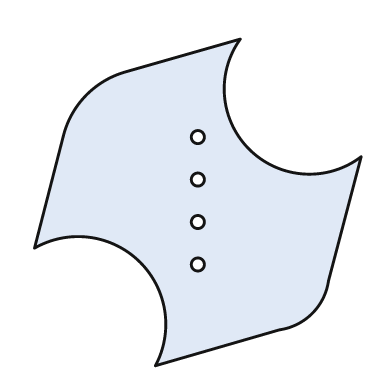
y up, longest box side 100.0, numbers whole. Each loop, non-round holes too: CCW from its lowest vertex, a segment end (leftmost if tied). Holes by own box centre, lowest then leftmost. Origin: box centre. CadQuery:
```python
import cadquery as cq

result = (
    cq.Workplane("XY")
    .moveTo(-13.0, -50.0)
    .lineTo(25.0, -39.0)
    .threePointArc((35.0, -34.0), (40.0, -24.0))
    .lineTo(50.0, 14.0)
    .threePointArc((16.0, 16.0), (13.0, 50.0))
    .lineTo(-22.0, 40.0)
    .threePointArc((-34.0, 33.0), (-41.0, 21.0))
    .lineTo(-50.0, -14.0)
    .threePointArc((-18.0, -18.0), (-13.0, -50.0))
    .close()
    .moveTo(0.0, -19.0)
    .circle(2.0)
    .moveTo(0.0, -6.0)
    .circle(2.0)
    .moveTo(0.0, 7.0)
    .circle(2.0)
    .moveTo(0.0, 20.0)
    .circle(2.0)
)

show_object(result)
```